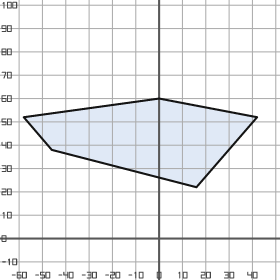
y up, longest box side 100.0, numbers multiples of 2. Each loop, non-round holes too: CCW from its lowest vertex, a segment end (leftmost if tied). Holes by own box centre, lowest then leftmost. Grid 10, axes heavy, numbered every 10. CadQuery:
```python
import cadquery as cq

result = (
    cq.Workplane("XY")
    .moveTo(16.0, 22.0)
    .lineTo(42.0, 52.0)
    .lineTo(0.0, 60.0)
    .lineTo(-58.0, 52.0)
    .lineTo(-46.0, 38.0)
    .close()
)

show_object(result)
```